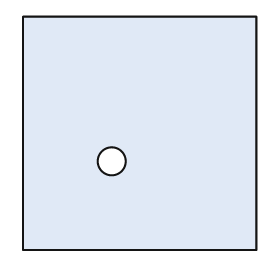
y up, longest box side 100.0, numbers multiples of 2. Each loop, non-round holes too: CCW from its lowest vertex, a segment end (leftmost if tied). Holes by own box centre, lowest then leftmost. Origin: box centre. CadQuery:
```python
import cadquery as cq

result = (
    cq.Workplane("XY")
    .moveTo(-50.0, -50.0)
    .lineTo(50.0, -50.0)
    .lineTo(50.0, 50.0)
    .lineTo(-50.0, 50.0)
    .close()
    .moveTo(-12.0, -12.0)
    .circle(6.0)
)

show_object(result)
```